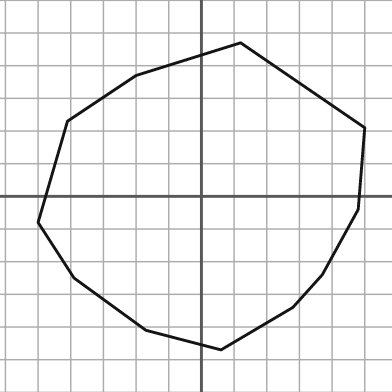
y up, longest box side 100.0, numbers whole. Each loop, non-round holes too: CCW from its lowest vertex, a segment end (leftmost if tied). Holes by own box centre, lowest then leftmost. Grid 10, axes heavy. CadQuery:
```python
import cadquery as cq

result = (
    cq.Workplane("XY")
    .moveTo(6.0, -47.0)
    .lineTo(28.0, -34.0)
    .lineTo(37.0, -24.0)
    .lineTo(48.0, -4.0)
    .lineTo(50.0, 21.0)
    .lineTo(12.0, 47.0)
    .lineTo(-20.0, 37.0)
    .lineTo(-41.0, 23.0)
    .lineTo(-50.0, -8.0)
    .lineTo(-39.0, -25.0)
    .lineTo(-17.0, -41.0)
    .close()
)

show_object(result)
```